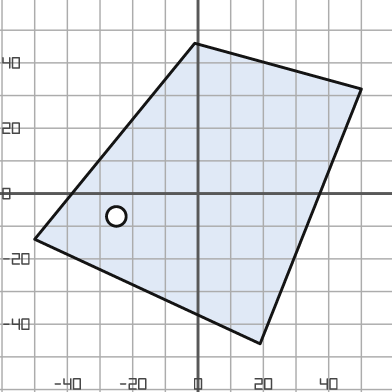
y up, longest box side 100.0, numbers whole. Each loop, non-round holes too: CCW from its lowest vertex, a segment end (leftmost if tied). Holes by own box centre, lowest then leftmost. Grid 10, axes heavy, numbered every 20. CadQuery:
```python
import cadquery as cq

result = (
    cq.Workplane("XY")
    .moveTo(19.0, -46.0)
    .lineTo(50.0, 32.0)
    .lineTo(-1.0, 46.0)
    .lineTo(-50.0, -14.0)
    .close()
    .moveTo(-25.0, -7.0)
    .circle(3.0)
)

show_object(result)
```